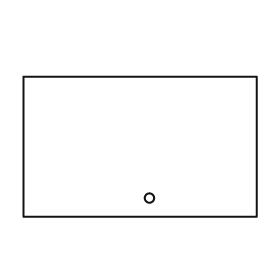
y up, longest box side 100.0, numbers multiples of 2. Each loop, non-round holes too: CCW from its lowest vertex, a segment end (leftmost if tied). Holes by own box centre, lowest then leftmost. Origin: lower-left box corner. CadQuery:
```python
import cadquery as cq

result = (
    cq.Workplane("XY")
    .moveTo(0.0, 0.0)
    .lineTo(100.0, 0.0)
    .lineTo(100.0, 60.0)
    .lineTo(0.0, 60.0)
    .close()
    .moveTo(54.0, 8.0)
    .circle(2.0)
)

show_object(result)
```